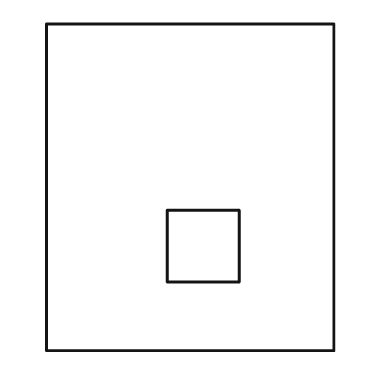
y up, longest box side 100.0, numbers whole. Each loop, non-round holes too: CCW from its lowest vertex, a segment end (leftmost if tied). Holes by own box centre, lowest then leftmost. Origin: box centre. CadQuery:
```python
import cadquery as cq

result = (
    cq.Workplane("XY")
    .moveTo(-44.0, -50.0)
    .lineTo(44.0, -50.0)
    .lineTo(44.0, 50.0)
    .lineTo(-44.0, 50.0)
    .close()
    .moveTo(-7.0, -29.0)
    .lineTo(15.0, -29.0)
    .lineTo(15.0, -7.0)
    .lineTo(-7.0, -7.0)
    .close()
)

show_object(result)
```